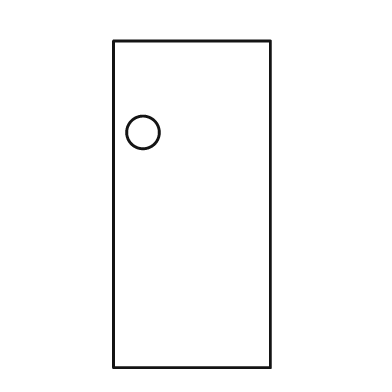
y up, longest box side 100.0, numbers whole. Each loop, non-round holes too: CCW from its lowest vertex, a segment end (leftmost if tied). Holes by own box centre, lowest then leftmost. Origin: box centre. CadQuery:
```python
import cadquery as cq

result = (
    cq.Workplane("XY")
    .moveTo(-24.0, -50.0)
    .lineTo(24.0, -50.0)
    .lineTo(24.0, 50.0)
    .lineTo(-24.0, 50.0)
    .close()
    .moveTo(-15.0, 22.0)
    .circle(5.0)
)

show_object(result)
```